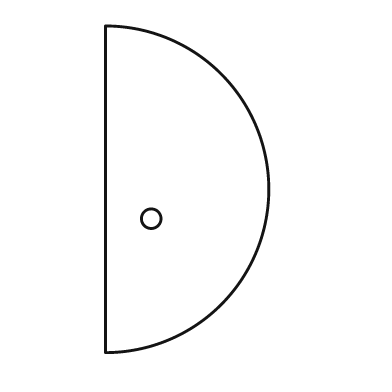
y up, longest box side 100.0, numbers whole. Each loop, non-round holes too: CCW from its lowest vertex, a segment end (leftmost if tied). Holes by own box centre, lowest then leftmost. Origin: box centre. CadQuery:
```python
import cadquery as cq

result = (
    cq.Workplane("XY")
    .moveTo(-25.0, -50.0)
    .threePointArc((25.0, 0.0), (-25.0, 50.0))
    .close()
    .moveTo(-11.0, -9.0)
    .circle(3.0)
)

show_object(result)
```